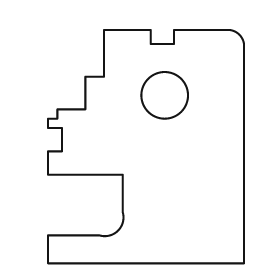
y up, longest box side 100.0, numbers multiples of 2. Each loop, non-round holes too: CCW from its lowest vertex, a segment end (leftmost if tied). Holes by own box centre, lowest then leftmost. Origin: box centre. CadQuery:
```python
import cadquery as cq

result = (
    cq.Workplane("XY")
    .moveTo(-42.0, -50.0)
    .lineTo(42.0, -50.0)
    .lineTo(42.0, 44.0)
    .threePointArc((40.0, 48.0), (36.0, 50.0))
    .lineTo(12.0, 50.0)
    .lineTo(12.0, 44.0)
    .lineTo(2.0, 44.0)
    .lineTo(2.0, 50.0)
    .lineTo(-18.0, 50.0)
    .lineTo(-18.0, 30.0)
    .lineTo(-26.0, 30.0)
    .lineTo(-26.0, 16.0)
    .lineTo(-38.0, 16.0)
    .lineTo(-38.0, 12.0)
    .lineTo(-42.0, 12.0)
    .lineTo(-42.0, 8.0)
    .lineTo(-36.0, 8.0)
    .lineTo(-36.0, -2.0)
    .lineTo(-42.0, -2.0)
    .lineTo(-42.0, -12.0)
    .lineTo(-10.0, -12.0)
    .lineTo(-10.0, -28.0)
    .threePointArc((-12.0, -36.0), (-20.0, -38.0))
    .lineTo(-42.0, -38.0)
    .close()
    .moveTo(8.0, 22.0)
    .circle(10.0)
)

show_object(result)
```